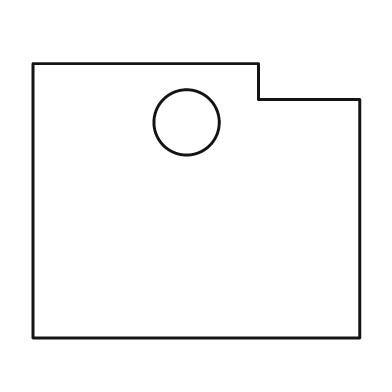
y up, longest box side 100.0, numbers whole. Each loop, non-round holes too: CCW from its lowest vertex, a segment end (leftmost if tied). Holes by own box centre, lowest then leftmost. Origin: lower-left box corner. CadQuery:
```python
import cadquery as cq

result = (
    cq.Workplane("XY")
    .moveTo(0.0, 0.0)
    .lineTo(100.0, 0.0)
    .lineTo(100.0, 73.0)
    .lineTo(69.0, 73.0)
    .lineTo(69.0, 84.0)
    .lineTo(0.0, 84.0)
    .close()
    .moveTo(47.0, 66.0)
    .circle(10.0)
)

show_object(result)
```